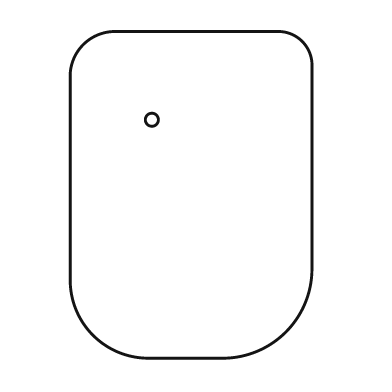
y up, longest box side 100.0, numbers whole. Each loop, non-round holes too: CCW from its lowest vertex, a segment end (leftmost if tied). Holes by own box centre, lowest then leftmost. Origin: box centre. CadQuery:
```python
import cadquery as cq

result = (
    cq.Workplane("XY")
    .moveTo(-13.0, -50.0)
    .lineTo(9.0, -50.0)
    .threePointArc((29.0, -42.0), (37.0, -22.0))
    .lineTo(37.0, 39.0)
    .threePointArc((34.0, 47.0), (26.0, 50.0))
    .lineTo(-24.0, 50.0)
    .threePointArc((-33.0, 46.0), (-37.0, 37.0))
    .lineTo(-37.0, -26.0)
    .threePointArc((-30.0, -43.0), (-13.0, -50.0))
    .close()
    .moveTo(-12.0, 23.0)
    .circle(2.0)
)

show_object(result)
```